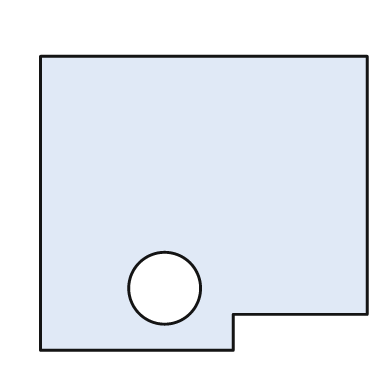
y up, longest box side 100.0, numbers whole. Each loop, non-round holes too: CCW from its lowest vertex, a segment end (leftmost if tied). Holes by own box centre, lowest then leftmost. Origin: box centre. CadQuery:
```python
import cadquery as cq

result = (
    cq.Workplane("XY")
    .moveTo(-50.0, -45.0)
    .lineTo(9.0, -45.0)
    .lineTo(9.0, -34.0)
    .lineTo(50.0, -34.0)
    .lineTo(50.0, 45.0)
    .lineTo(-50.0, 45.0)
    .close()
    .moveTo(-12.0, -26.0)
    .circle(11.0)
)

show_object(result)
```